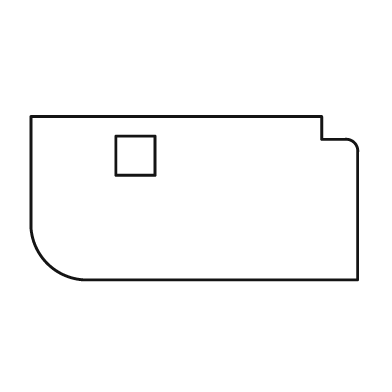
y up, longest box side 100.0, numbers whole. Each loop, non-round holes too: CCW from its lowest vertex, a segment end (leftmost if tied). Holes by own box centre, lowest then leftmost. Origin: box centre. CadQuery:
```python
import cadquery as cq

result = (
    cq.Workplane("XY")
    .moveTo(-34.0, -25.0)
    .lineTo(50.0, -25.0)
    .lineTo(50.0, 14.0)
    .threePointArc((49.0, 17.0), (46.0, 18.0))
    .lineTo(39.0, 18.0)
    .lineTo(39.0, 25.0)
    .lineTo(-50.0, 25.0)
    .lineTo(-50.0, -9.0)
    .threePointArc((-45.0, -20.0), (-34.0, -25.0))
    .close()
    .moveTo(-24.0, 7.0)
    .lineTo(-12.0, 7.0)
    .lineTo(-12.0, 19.0)
    .lineTo(-24.0, 19.0)
    .close()
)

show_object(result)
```